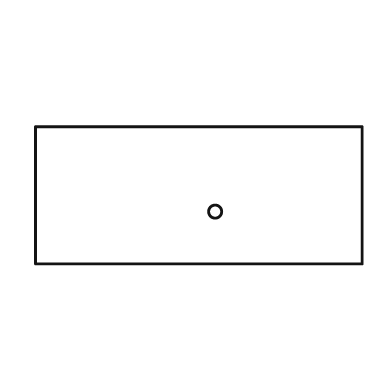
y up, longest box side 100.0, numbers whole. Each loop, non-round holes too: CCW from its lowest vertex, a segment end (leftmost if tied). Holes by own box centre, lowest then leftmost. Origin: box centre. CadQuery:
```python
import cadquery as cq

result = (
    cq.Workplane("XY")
    .moveTo(-50.0, -21.0)
    .lineTo(50.0, -21.0)
    .lineTo(50.0, 21.0)
    .lineTo(-50.0, 21.0)
    .close()
    .moveTo(5.0, -5.0)
    .circle(2.0)
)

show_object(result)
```